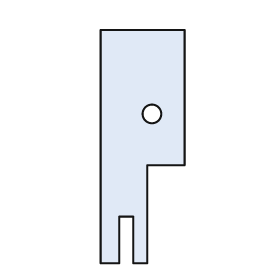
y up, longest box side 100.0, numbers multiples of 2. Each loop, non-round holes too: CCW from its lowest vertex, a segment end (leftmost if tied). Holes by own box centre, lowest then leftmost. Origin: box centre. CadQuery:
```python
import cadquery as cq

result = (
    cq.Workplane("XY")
    .moveTo(-18.0, -50.0)
    .lineTo(-10.0, -50.0)
    .lineTo(-10.0, -30.0)
    .lineTo(-4.0, -30.0)
    .lineTo(-4.0, -50.0)
    .lineTo(2.0, -50.0)
    .lineTo(2.0, -8.0)
    .lineTo(18.0, -8.0)
    .lineTo(18.0, 50.0)
    .lineTo(-18.0, 50.0)
    .close()
    .moveTo(4.0, 14.0)
    .circle(4.0)
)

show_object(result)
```